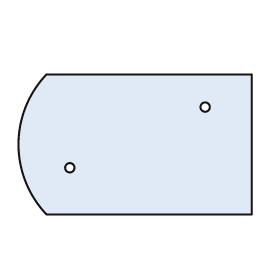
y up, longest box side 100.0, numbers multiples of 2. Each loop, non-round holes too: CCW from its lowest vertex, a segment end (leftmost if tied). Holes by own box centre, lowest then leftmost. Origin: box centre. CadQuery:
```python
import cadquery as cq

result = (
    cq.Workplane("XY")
    .moveTo(-38.0, -30.0)
    .lineTo(50.0, -30.0)
    .lineTo(50.0, 30.0)
    .lineTo(-38.0, 30.0)
    .threePointArc((-50.0, 0.0), (-38.0, -30.0))
    .close()
    .moveTo(-28.0, -10.0)
    .circle(2.0)
    .moveTo(30.0, 16.0)
    .circle(2.0)
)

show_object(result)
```